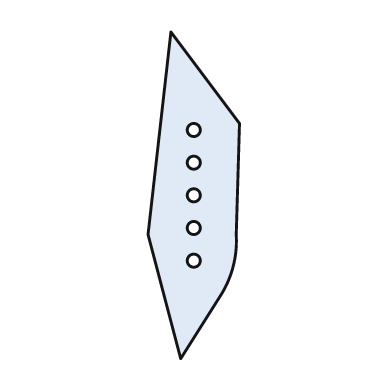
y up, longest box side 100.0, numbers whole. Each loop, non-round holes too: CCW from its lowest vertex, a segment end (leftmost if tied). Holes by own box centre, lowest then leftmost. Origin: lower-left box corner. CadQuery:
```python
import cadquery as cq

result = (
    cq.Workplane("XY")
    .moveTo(10.0, 0.0)
    .lineTo(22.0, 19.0)
    .threePointArc((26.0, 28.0), (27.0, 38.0))
    .lineTo(28.0, 72.0)
    .lineTo(7.0, 100.0)
    .lineTo(0.0, 38.0)
    .close()
    .moveTo(14.0, 30.0)
    .circle(2.0)
    .moveTo(14.0, 40.0)
    .circle(2.0)
    .moveTo(14.0, 50.0)
    .circle(2.0)
    .moveTo(14.0, 60.0)
    .circle(2.0)
    .moveTo(14.0, 70.0)
    .circle(2.0)
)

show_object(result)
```